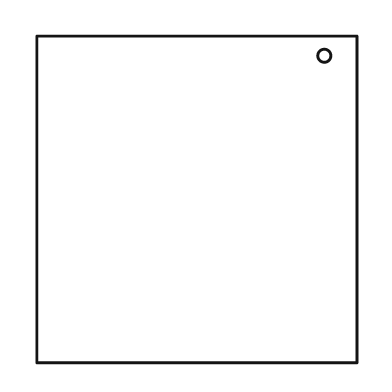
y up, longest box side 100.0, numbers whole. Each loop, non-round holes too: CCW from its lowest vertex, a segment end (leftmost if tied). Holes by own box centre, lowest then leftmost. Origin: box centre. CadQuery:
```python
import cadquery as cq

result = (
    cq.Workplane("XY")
    .moveTo(-49.0, -50.0)
    .lineTo(49.0, -50.0)
    .lineTo(49.0, 50.0)
    .lineTo(-49.0, 50.0)
    .close()
    .moveTo(39.0, 44.0)
    .circle(2.0)
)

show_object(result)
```